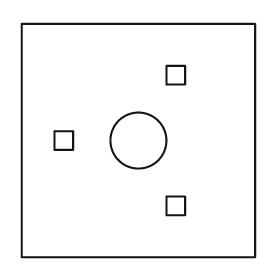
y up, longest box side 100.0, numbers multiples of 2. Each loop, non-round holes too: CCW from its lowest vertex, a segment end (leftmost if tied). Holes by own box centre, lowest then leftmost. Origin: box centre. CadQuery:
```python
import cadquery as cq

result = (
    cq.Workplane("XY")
    .moveTo(-50.0, -50.0)
    .lineTo(50.0, -50.0)
    .lineTo(50.0, 50.0)
    .lineTo(-50.0, 50.0)
    .close()
    .moveTo(12.0, -32.0)
    .lineTo(20.0, -32.0)
    .lineTo(20.0, -24.0)
    .lineTo(12.0, -24.0)
    .close()
    .moveTo(-36.0, -4.0)
    .lineTo(-28.0, -4.0)
    .lineTo(-28.0, 4.0)
    .lineTo(-36.0, 4.0)
    .close()
    .moveTo(0.0, 0.0)
    .circle(12.0)
    .moveTo(12.0, 24.0)
    .lineTo(20.0, 24.0)
    .lineTo(20.0, 32.0)
    .lineTo(12.0, 32.0)
    .close()
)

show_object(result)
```